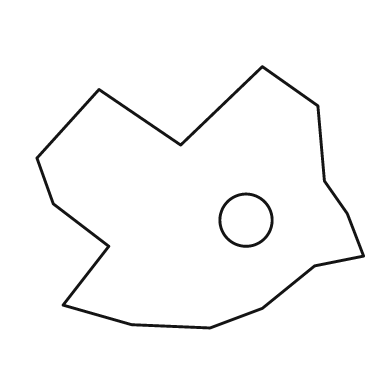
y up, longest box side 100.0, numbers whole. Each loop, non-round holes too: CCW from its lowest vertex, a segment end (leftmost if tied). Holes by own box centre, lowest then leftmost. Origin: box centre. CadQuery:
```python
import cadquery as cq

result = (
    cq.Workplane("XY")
    .moveTo(3.0, -40.0)
    .lineTo(19.0, -34.0)
    .lineTo(35.0, -21.0)
    .lineTo(50.0, -18.0)
    .lineTo(45.0, -5.0)
    .lineTo(38.0, 5.0)
    .lineTo(36.0, 28.0)
    .lineTo(19.0, 40.0)
    .lineTo(-6.0, 16.0)
    .lineTo(-31.0, 33.0)
    .lineTo(-50.0, 12.0)
    .lineTo(-45.0, -2.0)
    .lineTo(-28.0, -15.0)
    .lineTo(-42.0, -33.0)
    .lineTo(-21.0, -39.0)
    .close()
    .moveTo(14.0, -7.0)
    .circle(8.0)
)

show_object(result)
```